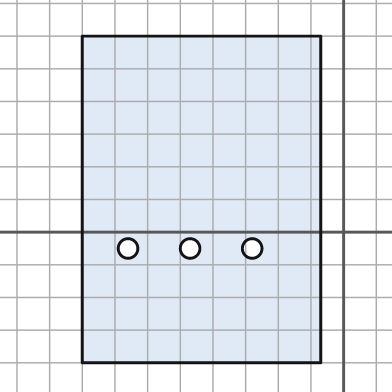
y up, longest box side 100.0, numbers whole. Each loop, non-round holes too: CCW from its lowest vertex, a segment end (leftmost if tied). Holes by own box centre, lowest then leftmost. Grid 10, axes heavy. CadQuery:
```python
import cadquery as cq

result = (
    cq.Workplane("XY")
    .moveTo(-80.0, -40.0)
    .lineTo(-7.0, -40.0)
    .lineTo(-7.0, 60.0)
    .lineTo(-80.0, 60.0)
    .close()
    .moveTo(-66.0, -5.0)
    .circle(3.0)
    .moveTo(-47.0, -5.0)
    .circle(3.0)
    .moveTo(-28.0, -5.0)
    .circle(3.0)
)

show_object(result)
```